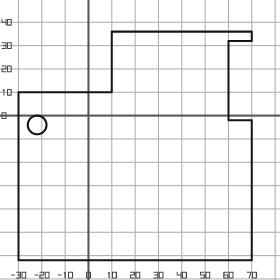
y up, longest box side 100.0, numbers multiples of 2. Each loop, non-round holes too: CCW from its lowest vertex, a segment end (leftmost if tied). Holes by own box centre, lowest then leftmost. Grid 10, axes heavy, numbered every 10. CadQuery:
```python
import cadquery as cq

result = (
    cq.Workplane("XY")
    .moveTo(-30.0, -62.0)
    .lineTo(70.0, -62.0)
    .lineTo(70.0, -2.0)
    .lineTo(60.0, -2.0)
    .lineTo(60.0, 32.0)
    .lineTo(70.0, 32.0)
    .lineTo(70.0, 36.0)
    .lineTo(10.0, 36.0)
    .lineTo(10.0, 10.0)
    .lineTo(-30.0, 10.0)
    .close()
    .moveTo(-22.0, -4.0)
    .circle(4.0)
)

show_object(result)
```